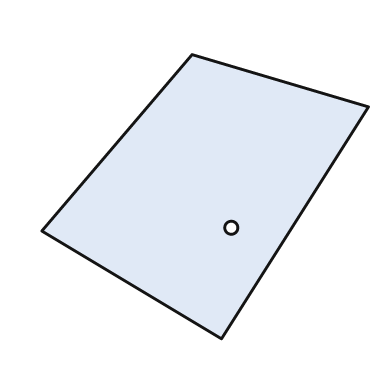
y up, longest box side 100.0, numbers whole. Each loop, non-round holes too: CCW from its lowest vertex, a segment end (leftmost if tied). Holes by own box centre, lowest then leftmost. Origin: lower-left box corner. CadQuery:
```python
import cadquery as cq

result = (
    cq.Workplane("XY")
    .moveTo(55.0, 0.0)
    .lineTo(100.0, 71.0)
    .lineTo(46.0, 87.0)
    .lineTo(0.0, 33.0)
    .close()
    .moveTo(58.0, 34.0)
    .circle(2.0)
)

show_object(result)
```